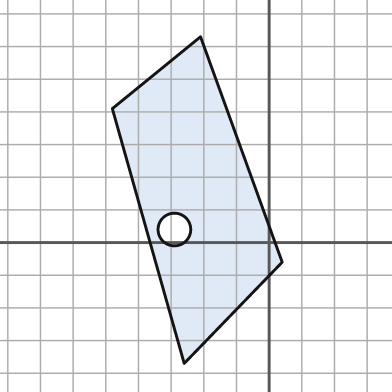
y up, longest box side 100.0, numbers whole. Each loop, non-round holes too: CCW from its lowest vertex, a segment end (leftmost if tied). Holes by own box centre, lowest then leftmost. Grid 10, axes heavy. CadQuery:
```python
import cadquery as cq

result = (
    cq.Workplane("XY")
    .moveTo(-26.0, -37.0)
    .lineTo(4.0, -6.0)
    .lineTo(-21.0, 63.0)
    .lineTo(-48.0, 41.0)
    .close()
    .moveTo(-29.0, 4.0)
    .circle(5.0)
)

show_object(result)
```